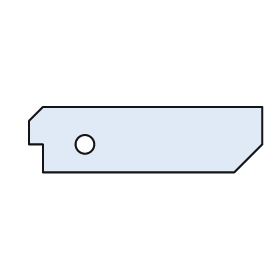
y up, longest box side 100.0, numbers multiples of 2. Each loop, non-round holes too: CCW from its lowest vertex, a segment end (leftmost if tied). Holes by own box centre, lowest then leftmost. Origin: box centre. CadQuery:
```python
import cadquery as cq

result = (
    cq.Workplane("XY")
    .moveTo(-44.0, -14.0)
    .lineTo(38.0, -14.0)
    .lineTo(50.0, -2.0)
    .lineTo(50.0, 14.0)
    .lineTo(-44.0, 14.0)
    .lineTo(-50.0, 8.0)
    .lineTo(-50.0, -2.0)
    .lineTo(-44.0, -2.0)
    .close()
    .moveTo(-26.0, -2.0)
    .circle(4.0)
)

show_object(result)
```